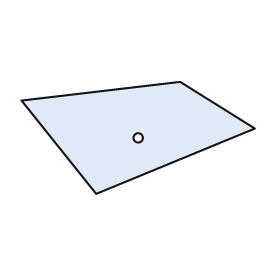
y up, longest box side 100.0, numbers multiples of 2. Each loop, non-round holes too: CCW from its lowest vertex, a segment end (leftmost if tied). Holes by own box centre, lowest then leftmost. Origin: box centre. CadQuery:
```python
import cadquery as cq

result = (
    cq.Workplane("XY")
    .moveTo(-18.0, -24.0)
    .lineTo(50.0, 4.0)
    .lineTo(18.0, 24.0)
    .lineTo(-50.0, 16.0)
    .close()
    .moveTo(0.0, 0.0)
    .circle(2.0)
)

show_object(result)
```